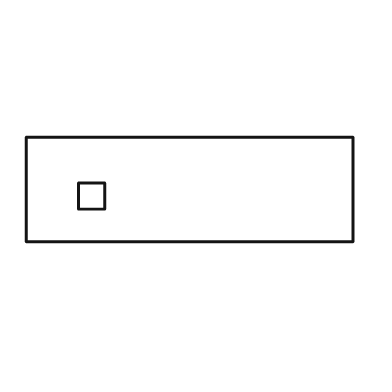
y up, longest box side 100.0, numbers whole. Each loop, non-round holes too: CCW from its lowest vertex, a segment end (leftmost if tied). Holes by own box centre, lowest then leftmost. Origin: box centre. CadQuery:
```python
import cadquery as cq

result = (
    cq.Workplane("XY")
    .moveTo(-50.0, -16.0)
    .lineTo(50.0, -16.0)
    .lineTo(50.0, 16.0)
    .lineTo(-50.0, 16.0)
    .close()
    .moveTo(-34.0, -6.0)
    .lineTo(-26.0, -6.0)
    .lineTo(-26.0, 2.0)
    .lineTo(-34.0, 2.0)
    .close()
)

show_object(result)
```